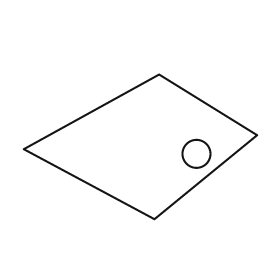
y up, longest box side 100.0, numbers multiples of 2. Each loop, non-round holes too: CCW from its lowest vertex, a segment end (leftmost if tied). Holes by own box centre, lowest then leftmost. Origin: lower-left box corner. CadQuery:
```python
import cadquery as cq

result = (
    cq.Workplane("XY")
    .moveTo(56.0, 0.0)
    .lineTo(100.0, 36.0)
    .lineTo(58.0, 62.0)
    .lineTo(0.0, 30.0)
    .close()
    .moveTo(74.0, 28.0)
    .circle(6.0)
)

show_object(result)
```